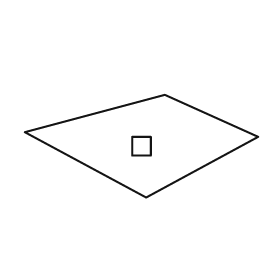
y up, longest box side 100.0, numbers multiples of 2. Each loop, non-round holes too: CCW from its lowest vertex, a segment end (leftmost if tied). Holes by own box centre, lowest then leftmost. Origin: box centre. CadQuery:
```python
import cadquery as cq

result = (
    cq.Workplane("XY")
    .moveTo(2.0, -22.0)
    .lineTo(50.0, 4.0)
    .lineTo(10.0, 22.0)
    .lineTo(-50.0, 6.0)
    .close()
    .moveTo(-4.0, -4.0)
    .lineTo(4.0, -4.0)
    .lineTo(4.0, 4.0)
    .lineTo(-4.0, 4.0)
    .close()
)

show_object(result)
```